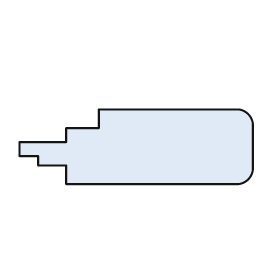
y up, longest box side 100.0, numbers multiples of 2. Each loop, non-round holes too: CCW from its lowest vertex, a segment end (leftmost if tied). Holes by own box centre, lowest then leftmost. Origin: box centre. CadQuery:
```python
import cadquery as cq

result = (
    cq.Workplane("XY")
    .moveTo(-30.0, -16.0)
    .lineTo(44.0, -16.0)
    .threePointArc((48.0, -14.0), (50.0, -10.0))
    .lineTo(50.0, 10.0)
    .threePointArc((48.0, 14.0), (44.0, 16.0))
    .lineTo(-16.0, 16.0)
    .lineTo(-16.0, 8.0)
    .lineTo(-30.0, 8.0)
    .lineTo(-30.0, 2.0)
    .lineTo(-50.0, 2.0)
    .lineTo(-50.0, -4.0)
    .lineTo(-42.0, -4.0)
    .lineTo(-42.0, -8.0)
    .lineTo(-30.0, -8.0)
    .close()
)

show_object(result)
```